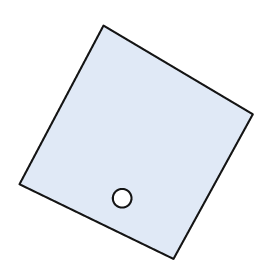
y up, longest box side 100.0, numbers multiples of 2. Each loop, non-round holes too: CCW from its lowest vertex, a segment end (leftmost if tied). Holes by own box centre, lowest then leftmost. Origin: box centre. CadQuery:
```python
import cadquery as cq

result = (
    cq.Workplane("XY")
    .moveTo(16.0, -50.0)
    .lineTo(50.0, 12.0)
    .lineTo(-14.0, 50.0)
    .lineTo(-50.0, -18.0)
    .close()
    .moveTo(-6.0, -24.0)
    .circle(4.0)
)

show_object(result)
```